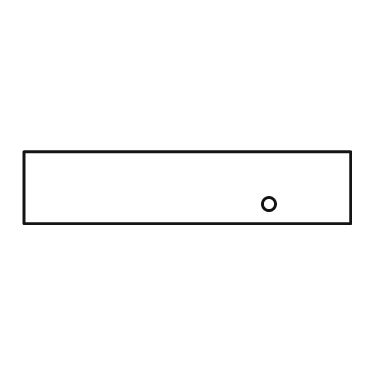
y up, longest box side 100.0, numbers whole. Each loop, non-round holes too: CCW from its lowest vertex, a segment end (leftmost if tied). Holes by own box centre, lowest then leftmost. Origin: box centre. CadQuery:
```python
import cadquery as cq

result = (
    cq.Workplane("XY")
    .moveTo(-50.0, -11.0)
    .lineTo(50.0, -11.0)
    .lineTo(50.0, 11.0)
    .lineTo(-50.0, 11.0)
    .close()
    .moveTo(25.0, -5.0)
    .circle(2.0)
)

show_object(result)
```